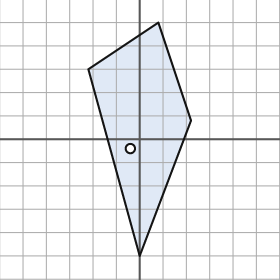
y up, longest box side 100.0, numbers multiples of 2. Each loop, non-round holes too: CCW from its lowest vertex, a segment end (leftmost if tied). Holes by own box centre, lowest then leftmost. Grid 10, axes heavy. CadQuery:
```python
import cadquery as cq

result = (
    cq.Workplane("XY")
    .moveTo(0.0, -50.0)
    .lineTo(22.0, 8.0)
    .lineTo(8.0, 50.0)
    .lineTo(-22.0, 30.0)
    .close()
    .moveTo(-4.0, -4.0)
    .circle(2.0)
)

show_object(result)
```